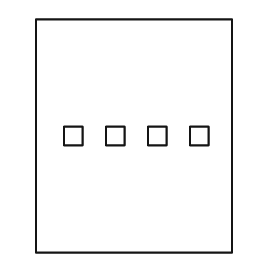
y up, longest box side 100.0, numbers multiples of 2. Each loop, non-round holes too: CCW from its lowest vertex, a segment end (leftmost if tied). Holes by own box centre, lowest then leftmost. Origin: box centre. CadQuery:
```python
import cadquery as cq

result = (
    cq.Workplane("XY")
    .moveTo(-42.0, -50.0)
    .lineTo(42.0, -50.0)
    .lineTo(42.0, 50.0)
    .lineTo(-42.0, 50.0)
    .close()
    .moveTo(-30.0, -4.0)
    .lineTo(-22.0, -4.0)
    .lineTo(-22.0, 4.0)
    .lineTo(-30.0, 4.0)
    .close()
    .moveTo(-12.0, -4.0)
    .lineTo(-4.0, -4.0)
    .lineTo(-4.0, 4.0)
    .lineTo(-12.0, 4.0)
    .close()
    .moveTo(6.0, -4.0)
    .lineTo(14.0, -4.0)
    .lineTo(14.0, 4.0)
    .lineTo(6.0, 4.0)
    .close()
    .moveTo(24.0, -4.0)
    .lineTo(32.0, -4.0)
    .lineTo(32.0, 4.0)
    .lineTo(24.0, 4.0)
    .close()
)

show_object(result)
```